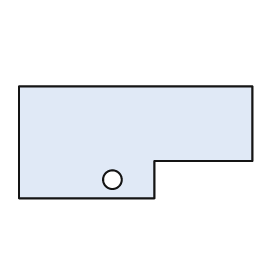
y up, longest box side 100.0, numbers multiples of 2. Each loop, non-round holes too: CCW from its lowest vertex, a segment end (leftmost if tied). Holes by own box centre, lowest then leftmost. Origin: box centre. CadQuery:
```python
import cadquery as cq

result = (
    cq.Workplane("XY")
    .moveTo(-50.0, -24.0)
    .lineTo(8.0, -24.0)
    .lineTo(8.0, -8.0)
    .lineTo(50.0, -8.0)
    .lineTo(50.0, 24.0)
    .lineTo(-50.0, 24.0)
    .close()
    .moveTo(-10.0, -16.0)
    .circle(4.0)
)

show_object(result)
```